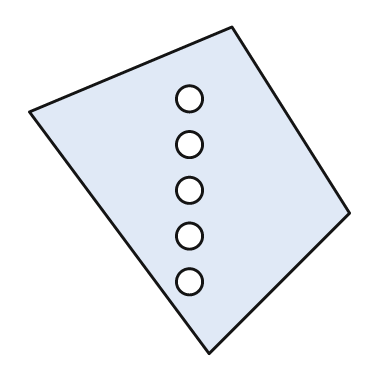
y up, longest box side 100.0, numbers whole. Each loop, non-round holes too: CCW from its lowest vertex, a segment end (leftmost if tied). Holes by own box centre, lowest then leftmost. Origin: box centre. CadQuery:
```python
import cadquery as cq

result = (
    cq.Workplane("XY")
    .moveTo(6.0, -50.0)
    .lineTo(49.0, -7.0)
    .lineTo(13.0, 50.0)
    .lineTo(-49.0, 24.0)
    .close()
    .moveTo(0.0, -28.0)
    .circle(4.0)
    .moveTo(0.0, -14.0)
    .circle(4.0)
    .moveTo(0.0, 0.0)
    .circle(4.0)
    .moveTo(0.0, 14.0)
    .circle(4.0)
    .moveTo(0.0, 28.0)
    .circle(4.0)
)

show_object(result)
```